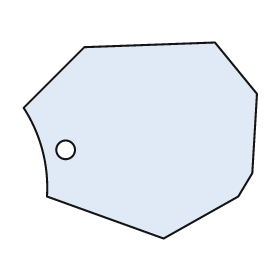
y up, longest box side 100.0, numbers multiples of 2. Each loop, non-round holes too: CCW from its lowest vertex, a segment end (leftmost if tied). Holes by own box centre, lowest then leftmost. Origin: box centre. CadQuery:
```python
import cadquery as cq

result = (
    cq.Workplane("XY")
    .moveTo(10.0, -42.0)
    .lineTo(42.0, -24.0)
    .lineTo(48.0, -14.0)
    .lineTo(50.0, 20.0)
    .lineTo(32.0, 42.0)
    .lineTo(-24.0, 40.0)
    .lineTo(-50.0, 14.0)
    .threePointArc((-42.0, -4.0), (-40.0, -24.0))
    .close()
    .moveTo(-32.0, -4.0)
    .circle(4.0)
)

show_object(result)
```